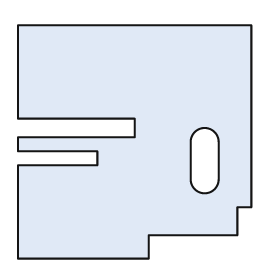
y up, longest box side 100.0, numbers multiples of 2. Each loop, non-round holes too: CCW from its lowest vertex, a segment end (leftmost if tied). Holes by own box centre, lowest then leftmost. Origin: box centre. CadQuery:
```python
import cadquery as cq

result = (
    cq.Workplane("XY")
    .moveTo(-50.0, -50.0)
    .lineTo(6.0, -50.0)
    .lineTo(6.0, -40.0)
    .lineTo(44.0, -40.0)
    .lineTo(44.0, -28.0)
    .lineTo(50.0, -28.0)
    .lineTo(50.0, 50.0)
    .lineTo(-50.0, 50.0)
    .lineTo(-50.0, 10.0)
    .lineTo(0.0, 10.0)
    .lineTo(0.0, 2.0)
    .lineTo(-50.0, 2.0)
    .lineTo(-50.0, -4.0)
    .lineTo(-16.0, -4.0)
    .lineTo(-16.0, -10.0)
    .lineTo(-50.0, -10.0)
    .close()
    .moveTo(24.0, -16.0)
    .threePointArc((30.0, -22.0), (36.0, -16.0))
    .lineTo(36.0, 0.0)
    .threePointArc((30.0, 6.0), (24.0, 0.0))
    .close()
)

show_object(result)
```